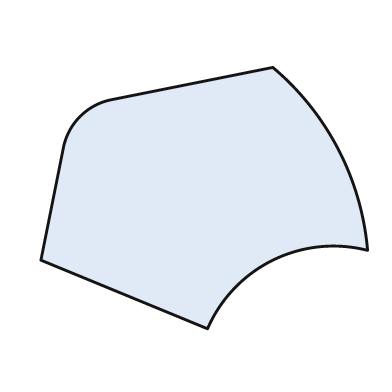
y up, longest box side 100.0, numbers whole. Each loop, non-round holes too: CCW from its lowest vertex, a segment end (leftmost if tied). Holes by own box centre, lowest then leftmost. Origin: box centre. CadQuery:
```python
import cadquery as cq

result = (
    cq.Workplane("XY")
    .moveTo(1.0, -40.0)
    .threePointArc((21.0, -19.0), (50.0, -16.0))
    .threePointArc((41.0, 15.0), (21.0, 40.0))
    .lineTo(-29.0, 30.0)
    .threePointArc((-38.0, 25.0), (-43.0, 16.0))
    .lineTo(-50.0, -19.0)
    .close()
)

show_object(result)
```